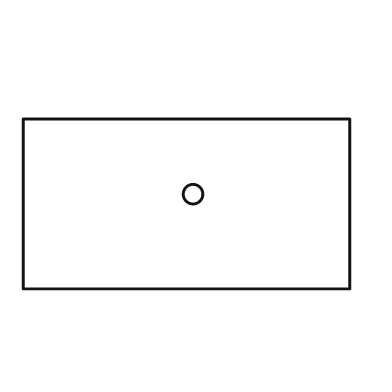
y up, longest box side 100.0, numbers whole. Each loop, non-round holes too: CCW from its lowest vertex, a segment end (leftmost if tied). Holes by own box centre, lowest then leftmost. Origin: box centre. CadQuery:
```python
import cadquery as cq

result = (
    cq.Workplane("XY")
    .moveTo(-50.0, -26.0)
    .lineTo(50.0, -26.0)
    .lineTo(50.0, 26.0)
    .lineTo(-50.0, 26.0)
    .close()
    .moveTo(2.0, 3.0)
    .circle(3.0)
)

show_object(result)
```